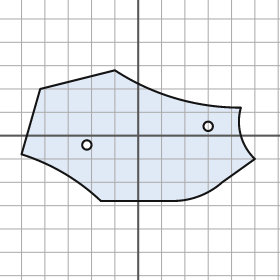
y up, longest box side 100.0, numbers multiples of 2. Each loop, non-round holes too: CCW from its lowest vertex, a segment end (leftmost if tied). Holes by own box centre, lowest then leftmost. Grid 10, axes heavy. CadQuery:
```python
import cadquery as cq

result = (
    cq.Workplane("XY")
    .moveTo(-16.0, -28.0)
    .lineTo(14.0, -28.0)
    .threePointArc((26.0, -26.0), (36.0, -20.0))
    .lineTo(50.0, -10.0)
    .threePointArc((44.0, 0.0), (44.0, 12.0))
    .threePointArc((16.0, 16.0), (-10.0, 28.0))
    .lineTo(-42.0, 20.0)
    .lineTo(-50.0, -8.0)
    .threePointArc((-32.0, -16.0), (-16.0, -28.0))
    .close()
    .moveTo(-22.0, -4.0)
    .circle(2.0)
    .moveTo(30.0, 4.0)
    .circle(2.0)
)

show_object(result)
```